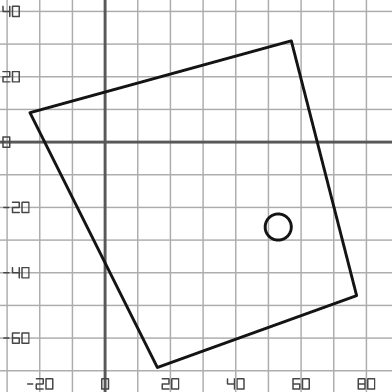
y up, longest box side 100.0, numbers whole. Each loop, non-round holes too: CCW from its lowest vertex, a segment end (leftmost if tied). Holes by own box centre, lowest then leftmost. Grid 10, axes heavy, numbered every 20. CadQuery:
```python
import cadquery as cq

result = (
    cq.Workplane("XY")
    .moveTo(16.0, -69.0)
    .lineTo(77.0, -47.0)
    .lineTo(57.0, 31.0)
    .lineTo(-23.0, 9.0)
    .close()
    .moveTo(53.0, -26.0)
    .circle(4.0)
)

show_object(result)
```